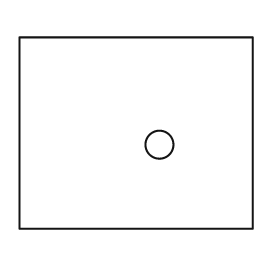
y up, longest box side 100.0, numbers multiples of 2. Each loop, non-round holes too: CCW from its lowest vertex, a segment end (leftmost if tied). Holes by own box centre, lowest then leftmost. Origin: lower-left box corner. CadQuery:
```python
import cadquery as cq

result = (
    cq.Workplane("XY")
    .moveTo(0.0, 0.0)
    .lineTo(100.0, 0.0)
    .lineTo(100.0, 82.0)
    .lineTo(0.0, 82.0)
    .close()
    .moveTo(60.0, 36.0)
    .circle(6.0)
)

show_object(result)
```